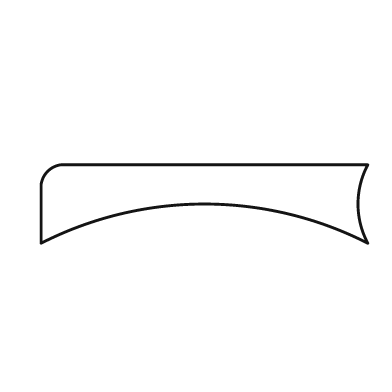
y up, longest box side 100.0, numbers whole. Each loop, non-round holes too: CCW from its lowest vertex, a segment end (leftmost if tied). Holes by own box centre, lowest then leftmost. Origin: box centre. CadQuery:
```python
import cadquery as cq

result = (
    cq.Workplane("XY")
    .moveTo(-50.0, -12.0)
    .threePointArc((0.0, 0.0), (50.0, -12.0))
    .threePointArc((47.0, 0.0), (50.0, 12.0))
    .lineTo(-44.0, 12.0)
    .threePointArc((-48.0, 10.0), (-50.0, 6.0))
    .close()
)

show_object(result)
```